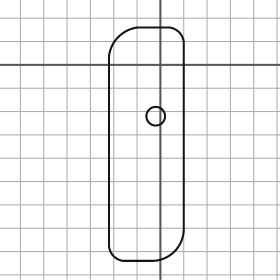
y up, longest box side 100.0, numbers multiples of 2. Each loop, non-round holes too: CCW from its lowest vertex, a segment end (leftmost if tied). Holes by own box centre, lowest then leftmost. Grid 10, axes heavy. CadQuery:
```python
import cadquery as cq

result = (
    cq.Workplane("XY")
    .moveTo(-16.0, -84.0)
    .lineTo(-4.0, -84.0)
    .threePointArc((6.0, -80.0), (10.0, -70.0))
    .lineTo(10.0, 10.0)
    .threePointArc((8.0, 14.0), (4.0, 16.0))
    .lineTo(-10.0, 16.0)
    .threePointArc((-18.0, 12.0), (-22.0, 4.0))
    .lineTo(-22.0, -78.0)
    .threePointArc((-20.0, -82.0), (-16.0, -84.0))
    .close()
    .moveTo(-2.0, -22.0)
    .circle(4.0)
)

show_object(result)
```